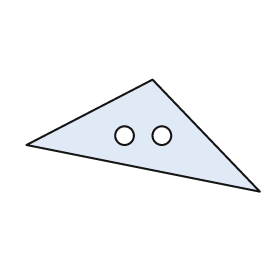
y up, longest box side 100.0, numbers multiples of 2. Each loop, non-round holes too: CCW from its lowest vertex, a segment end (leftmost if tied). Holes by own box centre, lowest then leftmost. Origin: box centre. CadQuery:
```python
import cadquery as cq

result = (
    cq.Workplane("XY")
    .moveTo(50.0, -24.0)
    .lineTo(4.0, 24.0)
    .lineTo(-50.0, -4.0)
    .close()
    .moveTo(-8.0, 0.0)
    .circle(4.0)
    .moveTo(8.0, 0.0)
    .circle(4.0)
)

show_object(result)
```